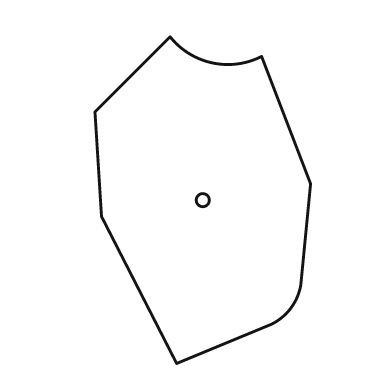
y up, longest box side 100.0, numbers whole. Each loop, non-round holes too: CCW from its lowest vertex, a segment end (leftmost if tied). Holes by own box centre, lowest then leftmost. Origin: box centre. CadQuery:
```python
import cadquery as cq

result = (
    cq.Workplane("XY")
    .moveTo(-8.0, -50.0)
    .lineTo(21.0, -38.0)
    .threePointArc((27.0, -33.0), (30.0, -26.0))
    .lineTo(33.0, 5.0)
    .lineTo(18.0, 44.0)
    .threePointArc((3.0, 42.0), (-10.0, 50.0))
    .lineTo(-33.0, 27.0)
    .lineTo(-31.0, -5.0)
    .close()
    .moveTo(0.0, 0.0)
    .circle(2.0)
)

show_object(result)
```